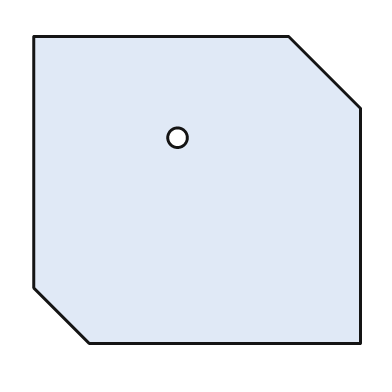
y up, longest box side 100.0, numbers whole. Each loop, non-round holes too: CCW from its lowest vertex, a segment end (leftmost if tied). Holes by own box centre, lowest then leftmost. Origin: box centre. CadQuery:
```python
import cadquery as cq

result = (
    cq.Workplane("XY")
    .moveTo(-33.0, -47.0)
    .lineTo(50.0, -47.0)
    .lineTo(50.0, 25.0)
    .lineTo(28.0, 47.0)
    .lineTo(-50.0, 47.0)
    .lineTo(-50.0, -30.0)
    .close()
    .moveTo(-6.0, 16.0)
    .circle(3.0)
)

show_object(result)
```